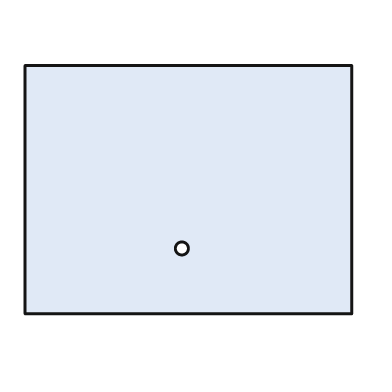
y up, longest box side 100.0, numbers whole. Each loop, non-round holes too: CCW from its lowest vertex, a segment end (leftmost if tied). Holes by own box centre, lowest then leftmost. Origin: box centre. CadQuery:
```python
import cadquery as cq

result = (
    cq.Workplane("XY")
    .moveTo(-50.0, -38.0)
    .lineTo(50.0, -38.0)
    .lineTo(50.0, 38.0)
    .lineTo(-50.0, 38.0)
    .close()
    .moveTo(-2.0, -18.0)
    .circle(2.0)
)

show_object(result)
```